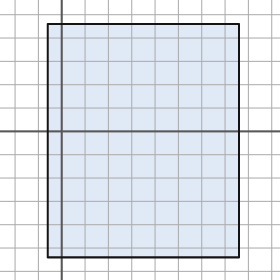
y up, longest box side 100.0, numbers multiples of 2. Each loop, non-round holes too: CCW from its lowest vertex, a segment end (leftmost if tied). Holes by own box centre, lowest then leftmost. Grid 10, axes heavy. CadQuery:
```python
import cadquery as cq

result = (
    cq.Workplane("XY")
    .moveTo(-6.0, -54.0)
    .lineTo(76.0, -54.0)
    .lineTo(76.0, 46.0)
    .lineTo(-6.0, 46.0)
    .close()
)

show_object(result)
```